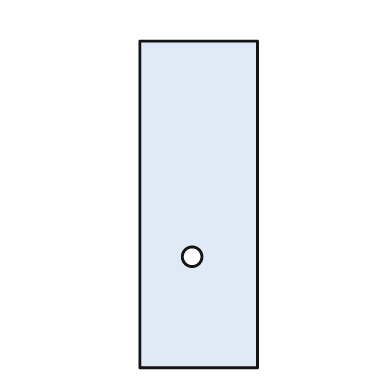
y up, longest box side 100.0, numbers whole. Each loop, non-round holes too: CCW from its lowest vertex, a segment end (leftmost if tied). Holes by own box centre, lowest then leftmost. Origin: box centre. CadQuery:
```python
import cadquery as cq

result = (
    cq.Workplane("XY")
    .moveTo(-18.0, -50.0)
    .lineTo(18.0, -50.0)
    .lineTo(18.0, 50.0)
    .lineTo(-18.0, 50.0)
    .close()
    .moveTo(-2.0, -16.0)
    .circle(3.0)
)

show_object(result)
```